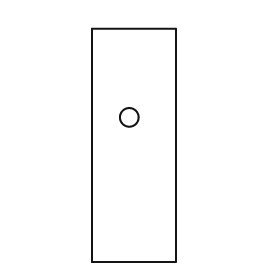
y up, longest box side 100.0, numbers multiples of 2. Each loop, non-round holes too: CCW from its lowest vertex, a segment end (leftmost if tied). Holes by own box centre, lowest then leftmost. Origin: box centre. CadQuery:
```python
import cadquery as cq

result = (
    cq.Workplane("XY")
    .moveTo(-18.0, -50.0)
    .lineTo(18.0, -50.0)
    .lineTo(18.0, 50.0)
    .lineTo(-18.0, 50.0)
    .close()
    .moveTo(-2.0, 12.0)
    .circle(4.0)
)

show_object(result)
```